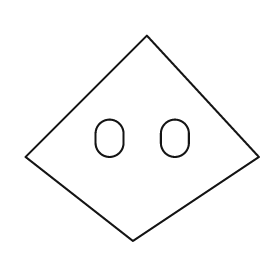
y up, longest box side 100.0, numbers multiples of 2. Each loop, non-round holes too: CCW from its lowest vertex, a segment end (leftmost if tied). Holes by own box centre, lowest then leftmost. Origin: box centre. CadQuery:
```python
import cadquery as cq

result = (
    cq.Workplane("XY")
    .moveTo(-4.0, -44.0)
    .lineTo(50.0, -8.0)
    .lineTo(2.0, 44.0)
    .lineTo(-50.0, -8.0)
    .close()
    .moveTo(-20.0, -2.0)
    .threePointArc((-14.0, -8.0), (-8.0, -2.0))
    .lineTo(-8.0, 2.0)
    .threePointArc((-14.0, 8.0), (-20.0, 2.0))
    .close()
    .moveTo(8.0, -2.0)
    .threePointArc((14.0, -8.0), (20.0, -2.0))
    .lineTo(20.0, 2.0)
    .threePointArc((14.0, 8.0), (8.0, 2.0))
    .close()
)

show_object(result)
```